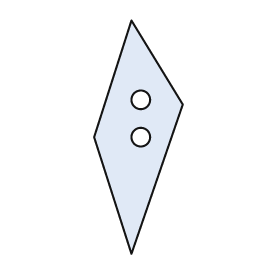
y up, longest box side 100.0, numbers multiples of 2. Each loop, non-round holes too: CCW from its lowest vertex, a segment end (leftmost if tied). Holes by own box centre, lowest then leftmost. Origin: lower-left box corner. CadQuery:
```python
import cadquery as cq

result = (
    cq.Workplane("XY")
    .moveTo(16.0, 0.0)
    .lineTo(38.0, 64.0)
    .lineTo(16.0, 100.0)
    .lineTo(0.0, 50.0)
    .close()
    .moveTo(20.0, 50.0)
    .circle(4.0)
    .moveTo(20.0, 66.0)
    .circle(4.0)
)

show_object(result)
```